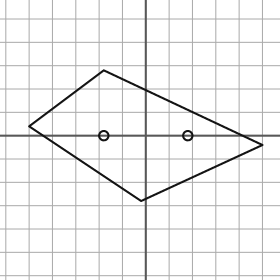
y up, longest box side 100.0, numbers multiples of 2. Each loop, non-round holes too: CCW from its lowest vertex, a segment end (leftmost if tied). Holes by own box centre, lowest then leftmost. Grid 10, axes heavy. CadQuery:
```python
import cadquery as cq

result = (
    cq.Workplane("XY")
    .moveTo(-2.0, -28.0)
    .lineTo(50.0, -4.0)
    .lineTo(-18.0, 28.0)
    .lineTo(-50.0, 4.0)
    .close()
    .moveTo(-18.0, 0.0)
    .circle(2.0)
    .moveTo(18.0, 0.0)
    .circle(2.0)
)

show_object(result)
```